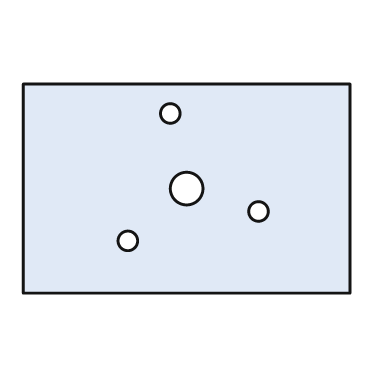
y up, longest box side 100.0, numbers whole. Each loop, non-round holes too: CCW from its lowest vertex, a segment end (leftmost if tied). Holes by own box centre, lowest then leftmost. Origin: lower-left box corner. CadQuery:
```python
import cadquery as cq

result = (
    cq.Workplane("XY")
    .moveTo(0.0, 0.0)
    .lineTo(100.0, 0.0)
    .lineTo(100.0, 64.0)
    .lineTo(0.0, 64.0)
    .close()
    .moveTo(32.0, 16.0)
    .circle(3.0)
    .moveTo(72.0, 25.0)
    .circle(3.0)
    .moveTo(50.0, 32.0)
    .circle(5.0)
    .moveTo(45.0, 55.0)
    .circle(3.0)
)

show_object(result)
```